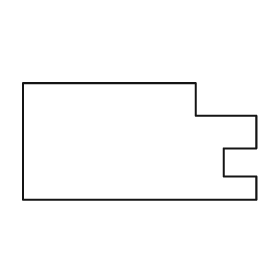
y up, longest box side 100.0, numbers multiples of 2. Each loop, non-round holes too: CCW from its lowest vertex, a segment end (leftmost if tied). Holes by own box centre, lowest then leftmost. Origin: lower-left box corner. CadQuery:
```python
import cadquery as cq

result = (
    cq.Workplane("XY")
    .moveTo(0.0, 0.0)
    .lineTo(100.0, 0.0)
    .lineTo(100.0, 10.0)
    .lineTo(86.0, 10.0)
    .lineTo(86.0, 22.0)
    .lineTo(100.0, 22.0)
    .lineTo(100.0, 36.0)
    .lineTo(74.0, 36.0)
    .lineTo(74.0, 50.0)
    .lineTo(0.0, 50.0)
    .close()
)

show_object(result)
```